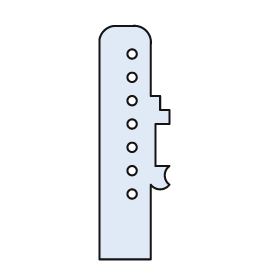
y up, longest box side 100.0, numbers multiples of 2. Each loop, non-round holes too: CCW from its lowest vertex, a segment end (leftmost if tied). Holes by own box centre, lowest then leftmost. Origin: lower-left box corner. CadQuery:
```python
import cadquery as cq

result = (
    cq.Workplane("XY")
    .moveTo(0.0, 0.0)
    .lineTo(22.0, 0.0)
    .lineTo(22.0, 32.0)
    .threePointArc((26.0, 30.0), (30.0, 32.0))
    .threePointArc((28.0, 36.0), (30.0, 40.0))
    .lineTo(24.0, 40.0)
    .lineTo(24.0, 58.0)
    .lineTo(30.0, 58.0)
    .lineTo(30.0, 64.0)
    .lineTo(26.0, 64.0)
    .lineTo(26.0, 70.0)
    .lineTo(22.0, 70.0)
    .lineTo(22.0, 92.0)
    .threePointArc((20.0, 98.0), (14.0, 100.0))
    .lineTo(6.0, 100.0)
    .threePointArc((2.0, 98.0), (0.0, 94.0))
    .close()
    .moveTo(14.0, 28.0)
    .circle(2.0)
    .moveTo(14.0, 38.0)
    .circle(2.0)
    .moveTo(14.0, 48.0)
    .circle(2.0)
    .moveTo(14.0, 58.0)
    .circle(2.0)
    .moveTo(14.0, 68.0)
    .circle(2.0)
    .moveTo(14.0, 78.0)
    .circle(2.0)
    .moveTo(14.0, 88.0)
    .circle(2.0)
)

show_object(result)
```